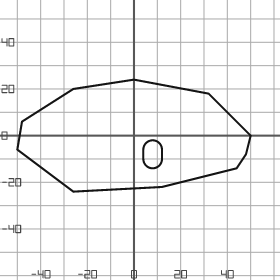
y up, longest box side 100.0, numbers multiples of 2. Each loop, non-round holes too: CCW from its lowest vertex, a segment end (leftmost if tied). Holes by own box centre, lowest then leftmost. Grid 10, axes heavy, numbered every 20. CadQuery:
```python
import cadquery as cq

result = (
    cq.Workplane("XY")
    .moveTo(-26.0, -24.0)
    .lineTo(12.0, -22.0)
    .lineTo(44.0, -14.0)
    .lineTo(48.0, -8.0)
    .lineTo(50.0, 0.0)
    .lineTo(32.0, 18.0)
    .lineTo(0.0, 24.0)
    .lineTo(-26.0, 20.0)
    .lineTo(-48.0, 6.0)
    .lineTo(-50.0, -6.0)
    .close()
    .moveTo(4.0, -10.0)
    .threePointArc((8.0, -14.0), (12.0, -10.0))
    .lineTo(12.0, -6.0)
    .threePointArc((8.0, -2.0), (4.0, -6.0))
    .close()
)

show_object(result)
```